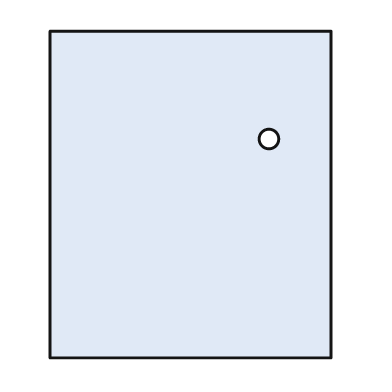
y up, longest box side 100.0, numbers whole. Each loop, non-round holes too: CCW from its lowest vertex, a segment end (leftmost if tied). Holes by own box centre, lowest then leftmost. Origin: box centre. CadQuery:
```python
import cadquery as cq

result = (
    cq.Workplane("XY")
    .moveTo(-43.0, -50.0)
    .lineTo(43.0, -50.0)
    .lineTo(43.0, 50.0)
    .lineTo(-43.0, 50.0)
    .close()
    .moveTo(24.0, 17.0)
    .circle(3.0)
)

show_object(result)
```